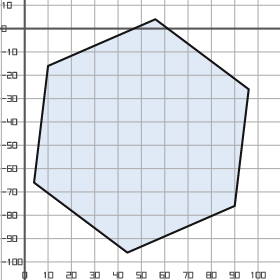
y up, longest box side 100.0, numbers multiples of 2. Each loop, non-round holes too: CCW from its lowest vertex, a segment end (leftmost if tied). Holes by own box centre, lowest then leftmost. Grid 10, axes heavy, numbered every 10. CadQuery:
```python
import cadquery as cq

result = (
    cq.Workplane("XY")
    .moveTo(44.0, -96.0)
    .lineTo(90.0, -76.0)
    .lineTo(96.0, -26.0)
    .lineTo(56.0, 4.0)
    .lineTo(10.0, -16.0)
    .lineTo(4.0, -66.0)
    .close()
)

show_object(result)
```